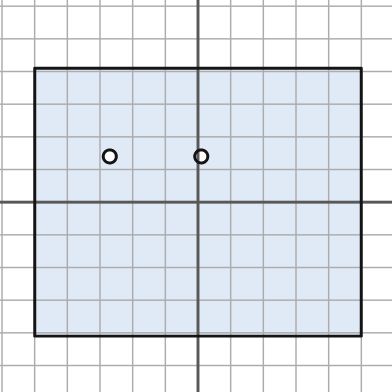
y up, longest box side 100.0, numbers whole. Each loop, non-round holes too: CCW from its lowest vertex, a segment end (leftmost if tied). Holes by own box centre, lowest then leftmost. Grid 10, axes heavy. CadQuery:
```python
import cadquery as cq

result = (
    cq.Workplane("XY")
    .moveTo(-50.0, -41.0)
    .lineTo(50.0, -41.0)
    .lineTo(50.0, 41.0)
    .lineTo(-50.0, 41.0)
    .close()
    .moveTo(-27.0, 14.0)
    .circle(2.0)
    .moveTo(1.0, 14.0)
    .circle(2.0)
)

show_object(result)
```